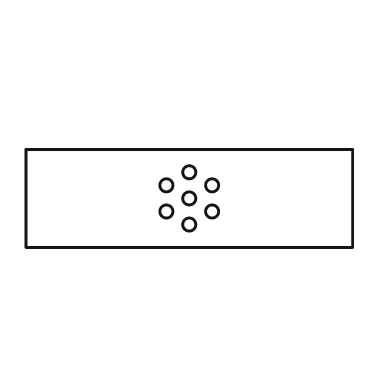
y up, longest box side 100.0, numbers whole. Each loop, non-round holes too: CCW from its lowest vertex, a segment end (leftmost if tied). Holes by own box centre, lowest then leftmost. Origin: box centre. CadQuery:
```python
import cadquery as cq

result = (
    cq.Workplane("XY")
    .moveTo(-50.0, -15.0)
    .lineTo(50.0, -15.0)
    .lineTo(50.0, 15.0)
    .lineTo(-50.0, 15.0)
    .close()
    .moveTo(0.0, -8.0)
    .circle(2.0)
    .moveTo(-7.0, -4.0)
    .circle(2.0)
    .moveTo(7.0, -4.0)
    .circle(2.0)
    .moveTo(0.0, 0.0)
    .circle(2.0)
    .moveTo(-7.0, 4.0)
    .circle(2.0)
    .moveTo(7.0, 4.0)
    .circle(2.0)
    .moveTo(0.0, 8.0)
    .circle(2.0)
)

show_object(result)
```